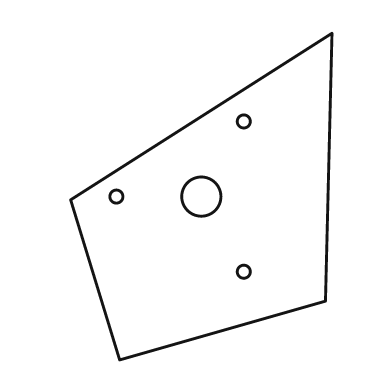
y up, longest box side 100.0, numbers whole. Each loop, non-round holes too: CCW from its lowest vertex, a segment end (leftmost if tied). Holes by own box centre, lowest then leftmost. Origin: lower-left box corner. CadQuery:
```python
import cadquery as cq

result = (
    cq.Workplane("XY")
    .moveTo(15.0, 0.0)
    .lineTo(78.0, 18.0)
    .lineTo(80.0, 100.0)
    .lineTo(0.0, 49.0)
    .close()
    .moveTo(53.0, 27.0)
    .circle(2.0)
    .moveTo(14.0, 50.0)
    .circle(2.0)
    .moveTo(40.0, 50.0)
    .circle(6.0)
    .moveTo(53.0, 73.0)
    .circle(2.0)
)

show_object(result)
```